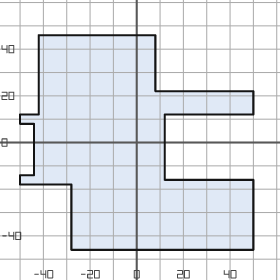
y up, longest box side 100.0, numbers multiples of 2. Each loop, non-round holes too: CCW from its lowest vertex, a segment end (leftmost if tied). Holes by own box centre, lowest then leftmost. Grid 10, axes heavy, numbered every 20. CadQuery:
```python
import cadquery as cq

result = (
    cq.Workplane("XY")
    .moveTo(-28.0, -46.0)
    .lineTo(50.0, -46.0)
    .lineTo(50.0, -16.0)
    .lineTo(12.0, -16.0)
    .lineTo(12.0, 12.0)
    .lineTo(50.0, 12.0)
    .lineTo(50.0, 22.0)
    .lineTo(8.0, 22.0)
    .lineTo(8.0, 46.0)
    .lineTo(-42.0, 46.0)
    .lineTo(-42.0, 12.0)
    .lineTo(-50.0, 12.0)
    .lineTo(-50.0, 8.0)
    .lineTo(-44.0, 8.0)
    .lineTo(-44.0, -14.0)
    .lineTo(-50.0, -14.0)
    .lineTo(-50.0, -18.0)
    .lineTo(-28.0, -18.0)
    .close()
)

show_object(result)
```